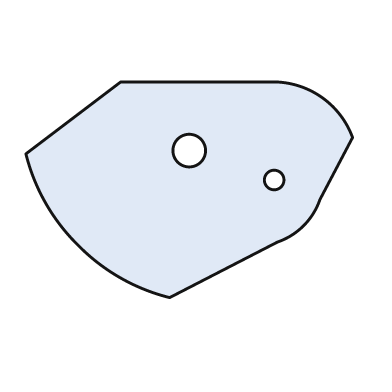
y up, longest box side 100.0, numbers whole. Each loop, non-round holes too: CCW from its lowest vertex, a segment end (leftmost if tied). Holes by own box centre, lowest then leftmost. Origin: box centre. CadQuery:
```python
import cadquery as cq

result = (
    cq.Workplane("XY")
    .moveTo(-6.0, -33.0)
    .lineTo(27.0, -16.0)
    .threePointArc((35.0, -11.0), (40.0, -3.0))
    .lineTo(50.0, 16.0)
    .threePointArc((41.0, 28.0), (27.0, 33.0))
    .lineTo(-21.0, 33.0)
    .lineTo(-50.0, 11.0)
    .threePointArc((-44.0, -4.0), (-34.0, -17.0))
    .threePointArc((-21.0, -27.0), (-6.0, -33.0))
    .close()
    .moveTo(26.0, 3.0)
    .circle(3.0)
    .moveTo(0.0, 12.0)
    .circle(5.0)
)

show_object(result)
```